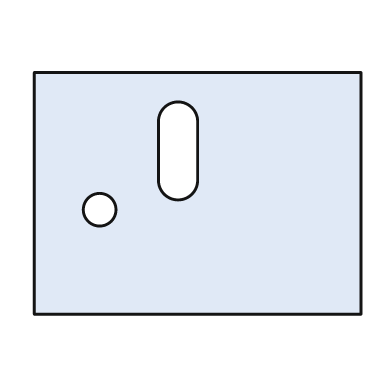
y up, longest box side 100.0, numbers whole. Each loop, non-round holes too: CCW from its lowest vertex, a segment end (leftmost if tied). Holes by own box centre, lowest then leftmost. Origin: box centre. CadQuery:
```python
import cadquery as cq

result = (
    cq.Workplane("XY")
    .moveTo(-50.0, -37.0)
    .lineTo(50.0, -37.0)
    .lineTo(50.0, 37.0)
    .lineTo(-50.0, 37.0)
    .close()
    .moveTo(-30.0, -5.0)
    .circle(5.0)
    .moveTo(-12.0, 4.0)
    .threePointArc((-6.0, -2.0), (0.0, 4.0))
    .lineTo(0.0, 22.0)
    .threePointArc((-6.0, 28.0), (-12.0, 22.0))
    .close()
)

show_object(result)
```